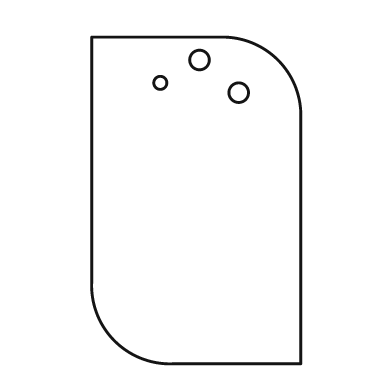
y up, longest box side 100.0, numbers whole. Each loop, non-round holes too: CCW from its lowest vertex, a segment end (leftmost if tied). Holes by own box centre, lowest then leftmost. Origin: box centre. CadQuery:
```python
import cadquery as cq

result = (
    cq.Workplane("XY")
    .moveTo(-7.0, -50.0)
    .lineTo(32.0, -50.0)
    .lineTo(32.0, 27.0)
    .threePointArc((25.0, 43.0), (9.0, 50.0))
    .lineTo(-32.0, 50.0)
    .lineTo(-32.0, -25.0)
    .threePointArc((-25.0, -43.0), (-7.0, -50.0))
    .close()
    .moveTo(13.0, 33.0)
    .circle(3.0)
    .moveTo(-11.0, 36.0)
    .circle(2.0)
    .moveTo(1.0, 43.0)
    .circle(3.0)
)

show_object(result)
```